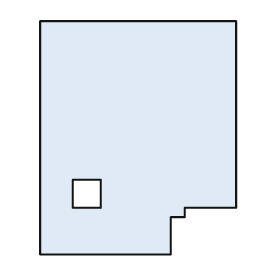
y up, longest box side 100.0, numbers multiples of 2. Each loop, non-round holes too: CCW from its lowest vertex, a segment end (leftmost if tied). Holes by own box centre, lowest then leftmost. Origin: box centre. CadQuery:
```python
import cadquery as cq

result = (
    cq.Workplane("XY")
    .moveTo(-42.0, -50.0)
    .lineTo(14.0, -50.0)
    .lineTo(14.0, -34.0)
    .lineTo(20.0, -34.0)
    .lineTo(20.0, -30.0)
    .lineTo(42.0, -30.0)
    .lineTo(42.0, 50.0)
    .lineTo(-42.0, 50.0)
    .close()
    .moveTo(-28.0, -30.0)
    .lineTo(-16.0, -30.0)
    .lineTo(-16.0, -18.0)
    .lineTo(-28.0, -18.0)
    .close()
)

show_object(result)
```